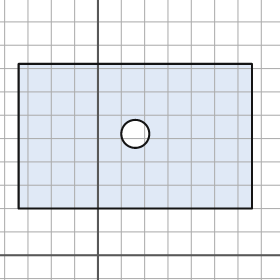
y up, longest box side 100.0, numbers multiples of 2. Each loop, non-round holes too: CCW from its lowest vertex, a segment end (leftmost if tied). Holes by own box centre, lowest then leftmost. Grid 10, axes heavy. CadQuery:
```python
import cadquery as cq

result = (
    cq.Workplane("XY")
    .moveTo(-34.0, 20.0)
    .lineTo(66.0, 20.0)
    .lineTo(66.0, 82.0)
    .lineTo(-34.0, 82.0)
    .close()
    .moveTo(16.0, 52.0)
    .circle(6.0)
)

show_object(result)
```